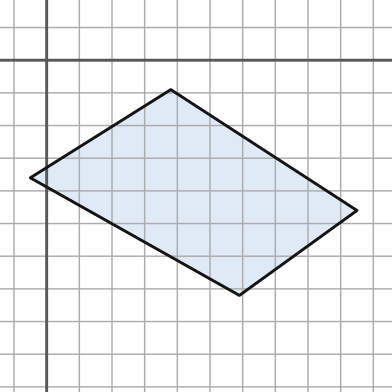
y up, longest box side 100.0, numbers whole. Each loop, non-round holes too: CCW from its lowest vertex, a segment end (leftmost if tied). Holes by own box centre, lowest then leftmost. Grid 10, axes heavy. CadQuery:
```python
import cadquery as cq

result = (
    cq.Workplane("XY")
    .moveTo(59.0, -72.0)
    .lineTo(95.0, -46.0)
    .lineTo(38.0, -9.0)
    .lineTo(-5.0, -36.0)
    .close()
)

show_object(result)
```